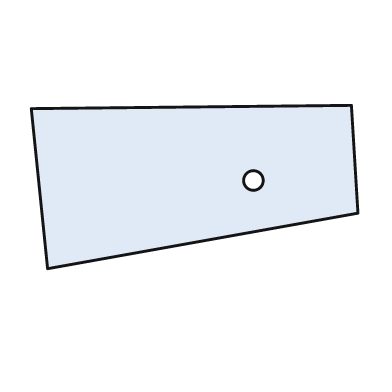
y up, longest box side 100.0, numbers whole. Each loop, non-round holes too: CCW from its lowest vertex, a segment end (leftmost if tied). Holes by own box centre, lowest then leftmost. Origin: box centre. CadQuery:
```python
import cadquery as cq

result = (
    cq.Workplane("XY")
    .moveTo(-45.0, -25.0)
    .lineTo(50.0, -8.0)
    .lineTo(48.0, 25.0)
    .lineTo(-50.0, 24.0)
    .close()
    .moveTo(18.0, 2.0)
    .circle(3.0)
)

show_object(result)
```